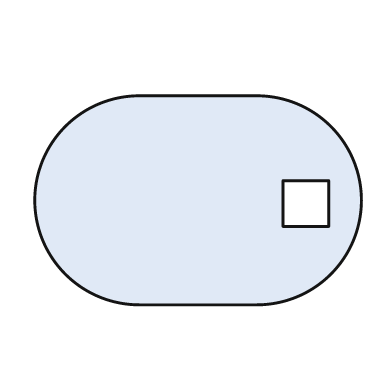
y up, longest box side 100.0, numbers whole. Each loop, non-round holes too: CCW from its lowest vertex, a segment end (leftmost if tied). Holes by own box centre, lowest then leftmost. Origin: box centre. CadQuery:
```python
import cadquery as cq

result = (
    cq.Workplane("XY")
    .moveTo(-18.0, -32.0)
    .lineTo(18.0, -32.0)
    .threePointArc((50.0, 0.0), (18.0, 32.0))
    .lineTo(-18.0, 32.0)
    .threePointArc((-50.0, 0.0), (-18.0, -32.0))
    .close()
    .moveTo(26.0, -8.0)
    .lineTo(40.0, -8.0)
    .lineTo(40.0, 6.0)
    .lineTo(26.0, 6.0)
    .close()
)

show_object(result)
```